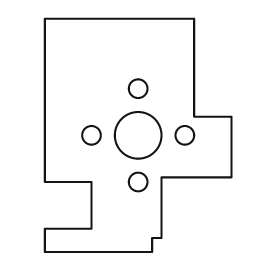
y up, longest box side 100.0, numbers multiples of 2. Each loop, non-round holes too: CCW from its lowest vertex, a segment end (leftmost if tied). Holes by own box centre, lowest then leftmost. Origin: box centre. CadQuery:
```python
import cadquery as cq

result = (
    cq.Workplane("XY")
    .moveTo(-40.0, -50.0)
    .lineTo(6.0, -50.0)
    .lineTo(6.0, -44.0)
    .lineTo(10.0, -44.0)
    .lineTo(10.0, -18.0)
    .lineTo(40.0, -18.0)
    .lineTo(40.0, 8.0)
    .lineTo(24.0, 8.0)
    .lineTo(24.0, 50.0)
    .lineTo(-40.0, 50.0)
    .lineTo(-40.0, -20.0)
    .lineTo(-20.0, -20.0)
    .lineTo(-20.0, -40.0)
    .lineTo(-40.0, -40.0)
    .close()
    .moveTo(0.0, -20.0)
    .circle(4.0)
    .moveTo(-20.0, 0.0)
    .circle(4.0)
    .moveTo(0.0, 0.0)
    .circle(10.0)
    .moveTo(20.0, 0.0)
    .circle(4.0)
    .moveTo(0.0, 20.0)
    .circle(4.0)
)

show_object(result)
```